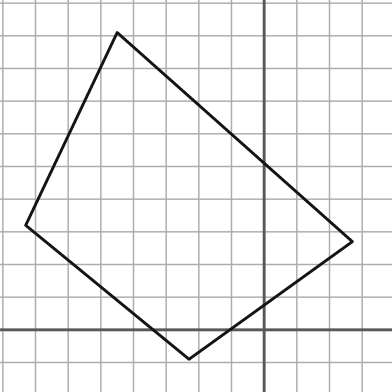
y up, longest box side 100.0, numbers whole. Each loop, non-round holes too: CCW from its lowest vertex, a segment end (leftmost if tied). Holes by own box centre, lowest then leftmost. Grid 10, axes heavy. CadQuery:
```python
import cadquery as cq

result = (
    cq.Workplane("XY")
    .moveTo(-23.0, -9.0)
    .lineTo(27.0, 27.0)
    .lineTo(-45.0, 91.0)
    .lineTo(-73.0, 32.0)
    .close()
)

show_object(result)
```